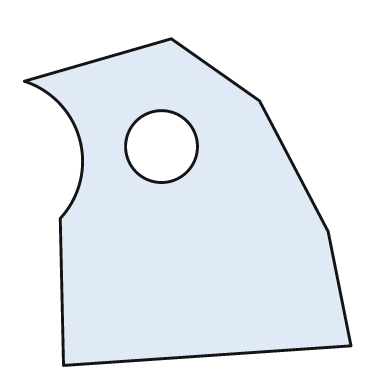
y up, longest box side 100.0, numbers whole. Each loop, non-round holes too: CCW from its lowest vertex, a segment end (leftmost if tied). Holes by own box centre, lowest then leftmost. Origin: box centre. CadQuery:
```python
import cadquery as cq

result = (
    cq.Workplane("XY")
    .moveTo(-38.0, -50.0)
    .lineTo(50.0, -44.0)
    .lineTo(43.0, -9.0)
    .lineTo(22.0, 31.0)
    .lineTo(-5.0, 50.0)
    .lineTo(-50.0, 37.0)
    .threePointArc((-33.0, 19.0), (-39.0, -5.0))
    .close()
    .moveTo(-8.0, 17.0)
    .circle(11.0)
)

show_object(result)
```